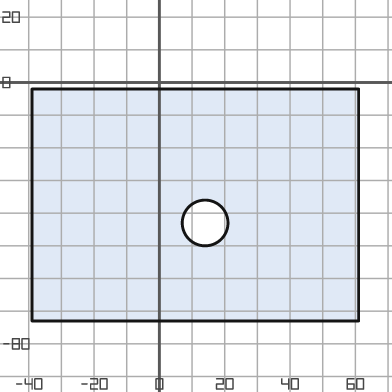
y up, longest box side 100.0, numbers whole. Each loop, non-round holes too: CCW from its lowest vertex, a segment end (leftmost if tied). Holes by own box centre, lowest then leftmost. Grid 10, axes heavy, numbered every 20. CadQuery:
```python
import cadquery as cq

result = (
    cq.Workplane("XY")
    .moveTo(-39.0, -73.0)
    .lineTo(61.0, -73.0)
    .lineTo(61.0, -2.0)
    .lineTo(-39.0, -2.0)
    .close()
    .moveTo(14.0, -43.0)
    .circle(7.0)
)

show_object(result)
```